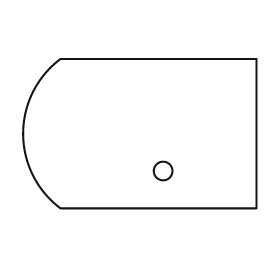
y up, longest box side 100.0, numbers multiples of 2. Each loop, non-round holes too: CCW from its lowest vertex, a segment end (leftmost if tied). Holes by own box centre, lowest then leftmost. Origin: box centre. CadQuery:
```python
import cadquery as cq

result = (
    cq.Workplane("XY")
    .moveTo(-34.0, -32.0)
    .lineTo(50.0, -32.0)
    .lineTo(50.0, 32.0)
    .lineTo(-34.0, 32.0)
    .threePointArc((-50.0, 0.0), (-34.0, -32.0))
    .close()
    .moveTo(10.0, -16.0)
    .circle(4.0)
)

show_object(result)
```